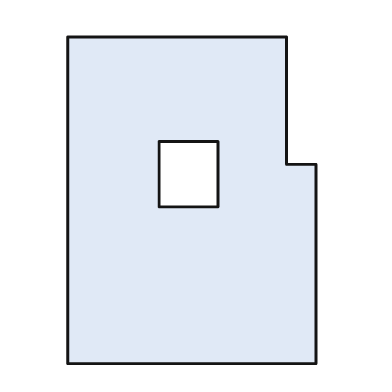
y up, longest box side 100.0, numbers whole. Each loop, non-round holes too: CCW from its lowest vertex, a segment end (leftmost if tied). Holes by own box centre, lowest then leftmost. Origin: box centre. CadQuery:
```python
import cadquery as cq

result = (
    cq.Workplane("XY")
    .moveTo(-38.0, -50.0)
    .lineTo(38.0, -50.0)
    .lineTo(38.0, 11.0)
    .lineTo(29.0, 11.0)
    .lineTo(29.0, 50.0)
    .lineTo(-38.0, 50.0)
    .close()
    .moveTo(-10.0, -2.0)
    .lineTo(8.0, -2.0)
    .lineTo(8.0, 18.0)
    .lineTo(-10.0, 18.0)
    .close()
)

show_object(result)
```